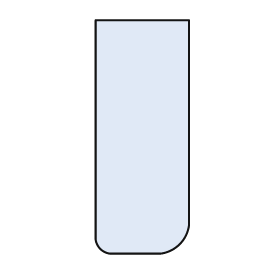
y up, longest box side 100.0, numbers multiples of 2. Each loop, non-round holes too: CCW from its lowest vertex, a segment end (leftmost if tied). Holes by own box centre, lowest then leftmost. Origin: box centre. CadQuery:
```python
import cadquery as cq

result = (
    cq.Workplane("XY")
    .moveTo(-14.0, -50.0)
    .lineTo(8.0, -50.0)
    .threePointArc((16.0, -46.0), (20.0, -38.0))
    .lineTo(20.0, 50.0)
    .lineTo(-20.0, 50.0)
    .lineTo(-20.0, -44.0)
    .threePointArc((-18.0, -48.0), (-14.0, -50.0))
    .close()
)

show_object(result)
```